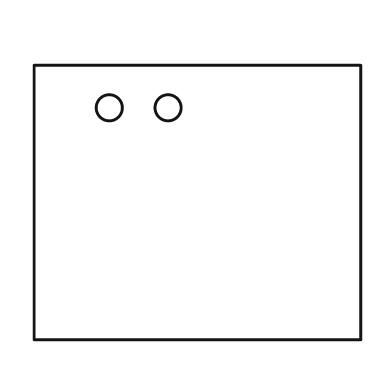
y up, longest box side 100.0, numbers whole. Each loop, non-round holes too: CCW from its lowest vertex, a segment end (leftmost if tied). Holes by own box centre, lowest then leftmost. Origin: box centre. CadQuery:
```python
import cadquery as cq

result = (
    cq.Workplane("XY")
    .moveTo(-50.0, -42.0)
    .lineTo(50.0, -42.0)
    .lineTo(50.0, 42.0)
    .lineTo(-50.0, 42.0)
    .close()
    .moveTo(-27.0, 29.0)
    .circle(4.0)
    .moveTo(-9.0, 29.0)
    .circle(4.0)
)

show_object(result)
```